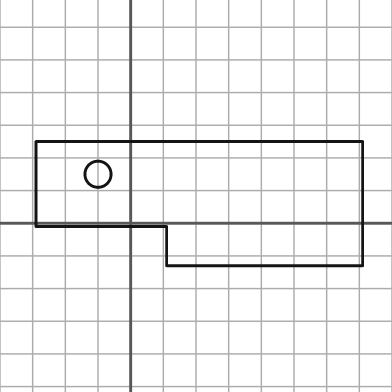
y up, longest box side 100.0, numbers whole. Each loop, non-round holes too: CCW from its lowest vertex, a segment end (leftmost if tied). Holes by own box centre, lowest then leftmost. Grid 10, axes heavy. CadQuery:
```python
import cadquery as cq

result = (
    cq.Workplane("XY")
    .moveTo(11.0, -13.0)
    .lineTo(71.0, -13.0)
    .lineTo(71.0, 25.0)
    .lineTo(-29.0, 25.0)
    .lineTo(-29.0, -1.0)
    .lineTo(11.0, -1.0)
    .close()
    .moveTo(-10.0, 15.0)
    .circle(4.0)
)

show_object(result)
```